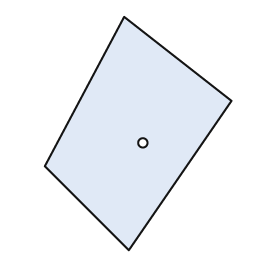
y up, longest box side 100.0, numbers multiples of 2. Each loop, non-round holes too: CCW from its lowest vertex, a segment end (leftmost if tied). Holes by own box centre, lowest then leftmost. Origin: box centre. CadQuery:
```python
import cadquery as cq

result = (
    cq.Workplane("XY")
    .moveTo(-4.0, -50.0)
    .lineTo(40.0, 14.0)
    .lineTo(-6.0, 50.0)
    .lineTo(-40.0, -14.0)
    .close()
    .moveTo(2.0, -4.0)
    .circle(2.0)
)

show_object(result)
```